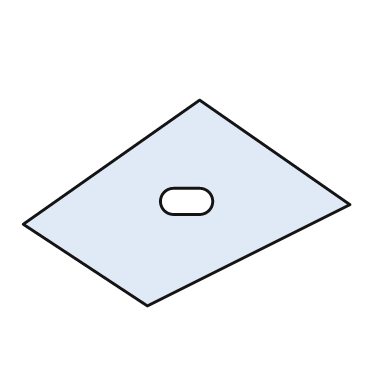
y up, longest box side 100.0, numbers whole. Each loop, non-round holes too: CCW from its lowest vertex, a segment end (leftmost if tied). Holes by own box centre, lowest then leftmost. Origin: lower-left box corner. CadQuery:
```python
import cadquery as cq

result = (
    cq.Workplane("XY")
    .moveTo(38.0, 0.0)
    .lineTo(100.0, 31.0)
    .lineTo(54.0, 63.0)
    .lineTo(0.0, 25.0)
    .close()
    .moveTo(46.0, 28.0)
    .lineTo(54.0, 28.0)
    .threePointArc((58.0, 32.0), (54.0, 36.0))
    .lineTo(46.0, 36.0)
    .threePointArc((42.0, 32.0), (46.0, 28.0))
    .close()
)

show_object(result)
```